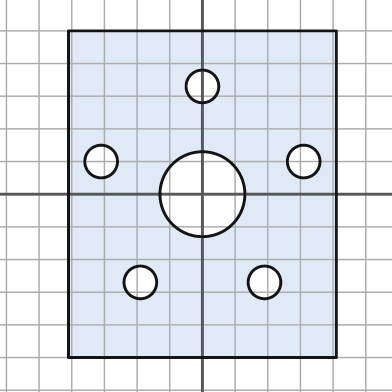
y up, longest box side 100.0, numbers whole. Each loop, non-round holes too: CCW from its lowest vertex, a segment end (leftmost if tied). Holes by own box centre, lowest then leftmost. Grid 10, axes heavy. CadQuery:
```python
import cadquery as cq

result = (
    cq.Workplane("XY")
    .moveTo(-41.0, -50.0)
    .lineTo(41.0, -50.0)
    .lineTo(41.0, 50.0)
    .lineTo(-41.0, 50.0)
    .close()
    .moveTo(-19.0, -27.0)
    .circle(5.0)
    .moveTo(19.0, -27.0)
    .circle(5.0)
    .moveTo(0.0, 0.0)
    .circle(13.0)
    .moveTo(-31.0, 10.0)
    .circle(5.0)
    .moveTo(31.0, 10.0)
    .circle(5.0)
    .moveTo(0.0, 33.0)
    .circle(5.0)
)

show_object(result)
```